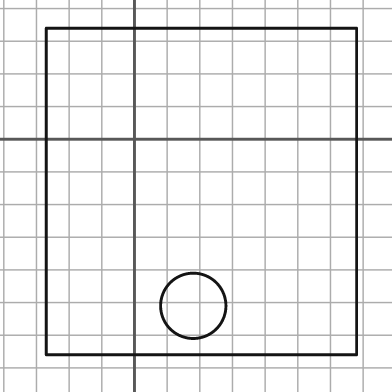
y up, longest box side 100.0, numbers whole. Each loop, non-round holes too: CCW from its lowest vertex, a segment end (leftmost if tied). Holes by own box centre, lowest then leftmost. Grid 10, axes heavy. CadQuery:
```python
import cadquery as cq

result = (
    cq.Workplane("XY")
    .moveTo(-27.0, -66.0)
    .lineTo(68.0, -66.0)
    .lineTo(68.0, 34.0)
    .lineTo(-27.0, 34.0)
    .close()
    .moveTo(18.0, -51.0)
    .circle(10.0)
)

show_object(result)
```